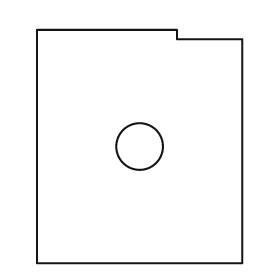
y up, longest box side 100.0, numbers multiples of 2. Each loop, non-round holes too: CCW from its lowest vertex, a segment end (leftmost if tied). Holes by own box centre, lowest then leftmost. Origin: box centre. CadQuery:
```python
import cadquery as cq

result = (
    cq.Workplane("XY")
    .moveTo(-44.0, -50.0)
    .lineTo(44.0, -50.0)
    .lineTo(44.0, 46.0)
    .lineTo(16.0, 46.0)
    .lineTo(16.0, 50.0)
    .lineTo(-44.0, 50.0)
    .close()
    .moveTo(0.0, 0.0)
    .circle(10.0)
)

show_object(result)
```